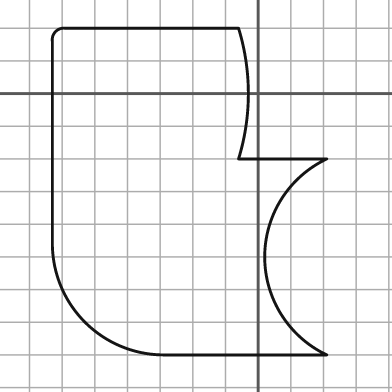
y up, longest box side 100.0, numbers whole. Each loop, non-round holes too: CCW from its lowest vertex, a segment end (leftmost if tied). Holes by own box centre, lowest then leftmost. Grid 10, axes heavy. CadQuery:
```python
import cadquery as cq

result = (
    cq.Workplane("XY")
    .moveTo(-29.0, -80.0)
    .lineTo(21.0, -80.0)
    .threePointArc((2.0, -50.0), (21.0, -20.0))
    .lineTo(-6.0, -20.0)
    .threePointArc((-3.0, 0.0), (-6.0, 20.0))
    .lineTo(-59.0, 20.0)
    .threePointArc((-62.0, 19.0), (-63.0, 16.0))
    .lineTo(-63.0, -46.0)
    .threePointArc((-53.0, -70.0), (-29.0, -80.0))
    .close()
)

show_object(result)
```